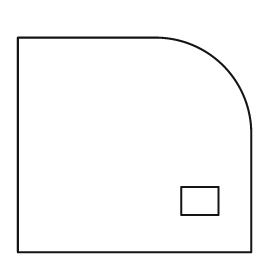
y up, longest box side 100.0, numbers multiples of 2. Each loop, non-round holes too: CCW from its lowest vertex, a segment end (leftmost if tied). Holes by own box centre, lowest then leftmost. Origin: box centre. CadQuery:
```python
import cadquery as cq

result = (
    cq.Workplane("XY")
    .moveTo(-50.0, -46.0)
    .lineTo(50.0, -46.0)
    .lineTo(50.0, 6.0)
    .threePointArc((38.0, 34.0), (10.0, 46.0))
    .lineTo(-50.0, 46.0)
    .close()
    .moveTo(20.0, -30.0)
    .lineTo(36.0, -30.0)
    .lineTo(36.0, -18.0)
    .lineTo(20.0, -18.0)
    .close()
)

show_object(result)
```